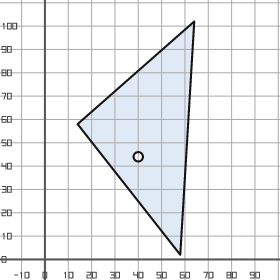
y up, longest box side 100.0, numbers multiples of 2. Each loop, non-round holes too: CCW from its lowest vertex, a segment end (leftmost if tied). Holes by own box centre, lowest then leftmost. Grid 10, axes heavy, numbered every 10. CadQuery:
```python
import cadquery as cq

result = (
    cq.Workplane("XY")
    .moveTo(58.0, 2.0)
    .lineTo(64.0, 102.0)
    .lineTo(14.0, 58.0)
    .close()
    .moveTo(40.0, 44.0)
    .circle(2.0)
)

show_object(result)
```